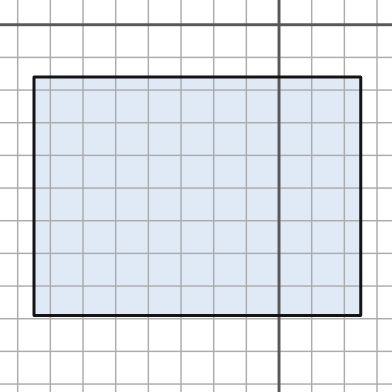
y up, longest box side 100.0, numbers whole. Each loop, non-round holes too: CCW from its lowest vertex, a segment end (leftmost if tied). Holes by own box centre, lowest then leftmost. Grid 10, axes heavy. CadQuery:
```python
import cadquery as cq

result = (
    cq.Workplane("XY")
    .moveTo(-75.0, -89.0)
    .lineTo(25.0, -89.0)
    .lineTo(25.0, -16.0)
    .lineTo(-75.0, -16.0)
    .close()
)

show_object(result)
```